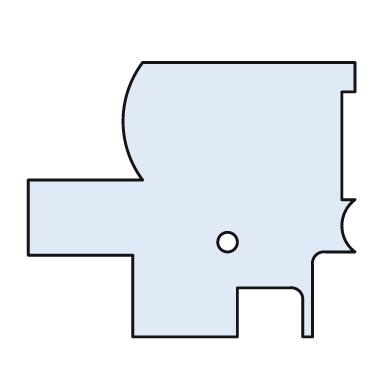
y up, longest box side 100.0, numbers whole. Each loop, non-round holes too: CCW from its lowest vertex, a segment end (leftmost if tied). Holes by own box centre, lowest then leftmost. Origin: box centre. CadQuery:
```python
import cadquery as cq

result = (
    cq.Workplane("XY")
    .moveTo(-18.0, -42.0)
    .lineTo(14.0, -42.0)
    .lineTo(14.0, -27.0)
    .lineTo(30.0, -27.0)
    .threePointArc((33.0, -28.0), (34.0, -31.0))
    .lineTo(34.0, -42.0)
    .lineTo(37.0, -42.0)
    .lineTo(37.0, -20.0)
    .threePointArc((38.0, -17.0), (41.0, -16.0))
    .lineTo(50.0, -16.0)
    .threePointArc((46.0, -8.0), (50.0, 0.0))
    .lineTo(46.0, 0.0)
    .lineTo(46.0, 33.0)
    .lineTo(50.0, 33.0)
    .lineTo(50.0, 42.0)
    .lineTo(-15.0, 42.0)
    .threePointArc((-21.0, 24.0), (-15.0, 6.0))
    .lineTo(-50.0, 6.0)
    .lineTo(-50.0, -17.0)
    .lineTo(-18.0, -17.0)
    .close()
    .moveTo(11.0, -13.0)
    .circle(3.0)
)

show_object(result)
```